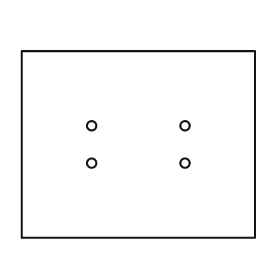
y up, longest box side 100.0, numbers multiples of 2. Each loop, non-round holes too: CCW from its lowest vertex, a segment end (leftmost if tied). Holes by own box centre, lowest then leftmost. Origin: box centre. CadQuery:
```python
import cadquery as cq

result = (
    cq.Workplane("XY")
    .moveTo(-50.0, -40.0)
    .lineTo(50.0, -40.0)
    .lineTo(50.0, 40.0)
    .lineTo(-50.0, 40.0)
    .close()
    .moveTo(-20.0, -8.0)
    .circle(2.0)
    .moveTo(20.0, -8.0)
    .circle(2.0)
    .moveTo(-20.0, 8.0)
    .circle(2.0)
    .moveTo(20.0, 8.0)
    .circle(2.0)
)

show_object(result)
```